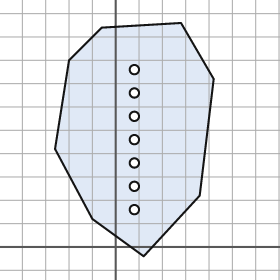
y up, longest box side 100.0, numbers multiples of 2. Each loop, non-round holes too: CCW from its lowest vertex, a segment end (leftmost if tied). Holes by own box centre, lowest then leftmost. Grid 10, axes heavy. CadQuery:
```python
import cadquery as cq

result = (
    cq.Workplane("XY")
    .moveTo(12.0, -4.0)
    .lineTo(36.0, 22.0)
    .lineTo(42.0, 72.0)
    .lineTo(28.0, 96.0)
    .lineTo(-6.0, 94.0)
    .lineTo(-20.0, 80.0)
    .lineTo(-26.0, 42.0)
    .lineTo(-10.0, 12.0)
    .close()
    .moveTo(8.0, 16.0)
    .circle(2.0)
    .moveTo(8.0, 26.0)
    .circle(2.0)
    .moveTo(8.0, 36.0)
    .circle(2.0)
    .moveTo(8.0, 46.0)
    .circle(2.0)
    .moveTo(8.0, 56.0)
    .circle(2.0)
    .moveTo(8.0, 66.0)
    .circle(2.0)
    .moveTo(8.0, 76.0)
    .circle(2.0)
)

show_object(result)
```